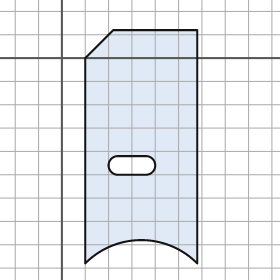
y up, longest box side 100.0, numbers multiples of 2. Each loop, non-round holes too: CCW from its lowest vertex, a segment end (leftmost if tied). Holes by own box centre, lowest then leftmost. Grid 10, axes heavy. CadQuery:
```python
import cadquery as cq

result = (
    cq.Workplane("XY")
    .moveTo(10.0, -88.0)
    .threePointArc((34.0, -78.0), (58.0, -88.0))
    .lineTo(58.0, 12.0)
    .lineTo(22.0, 12.0)
    .lineTo(10.0, 0.0)
    .close()
    .moveTo(24.0, -50.0)
    .lineTo(36.0, -50.0)
    .threePointArc((40.0, -46.0), (36.0, -42.0))
    .lineTo(24.0, -42.0)
    .threePointArc((20.0, -46.0), (24.0, -50.0))
    .close()
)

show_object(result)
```